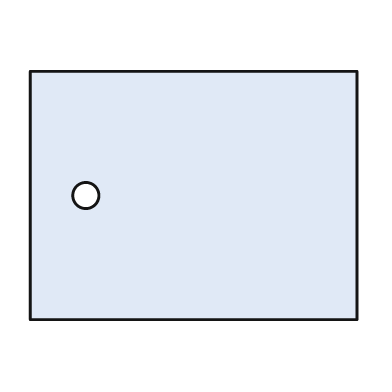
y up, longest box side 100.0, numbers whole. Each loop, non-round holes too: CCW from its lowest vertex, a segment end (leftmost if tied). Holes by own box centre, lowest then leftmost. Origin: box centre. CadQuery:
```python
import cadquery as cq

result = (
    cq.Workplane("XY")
    .moveTo(-50.0, -38.0)
    .lineTo(50.0, -38.0)
    .lineTo(50.0, 38.0)
    .lineTo(-50.0, 38.0)
    .close()
    .moveTo(-33.0, 0.0)
    .circle(4.0)
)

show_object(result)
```